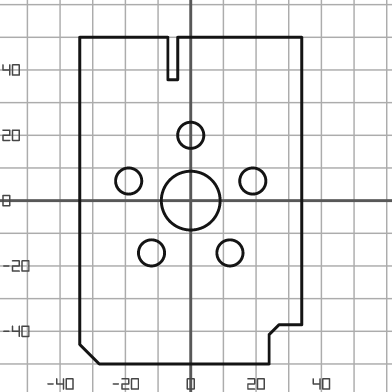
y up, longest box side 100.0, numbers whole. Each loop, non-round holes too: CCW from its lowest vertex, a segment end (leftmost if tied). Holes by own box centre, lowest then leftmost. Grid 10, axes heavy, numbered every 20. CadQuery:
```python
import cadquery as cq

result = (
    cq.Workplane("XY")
    .moveTo(-28.0, -50.0)
    .lineTo(24.0, -50.0)
    .lineTo(24.0, -41.0)
    .lineTo(27.0, -38.0)
    .lineTo(34.0, -38.0)
    .lineTo(34.0, 50.0)
    .lineTo(-4.0, 50.0)
    .lineTo(-4.0, 37.0)
    .lineTo(-7.0, 37.0)
    .lineTo(-7.0, 50.0)
    .lineTo(-34.0, 50.0)
    .lineTo(-34.0, -44.0)
    .close()
    .moveTo(-12.0, -16.0)
    .circle(4.0)
    .moveTo(12.0, -16.0)
    .circle(4.0)
    .moveTo(0.0, 0.0)
    .circle(9.0)
    .moveTo(-19.0, 6.0)
    .circle(4.0)
    .moveTo(19.0, 6.0)
    .circle(4.0)
    .moveTo(0.0, 20.0)
    .circle(4.0)
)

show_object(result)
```